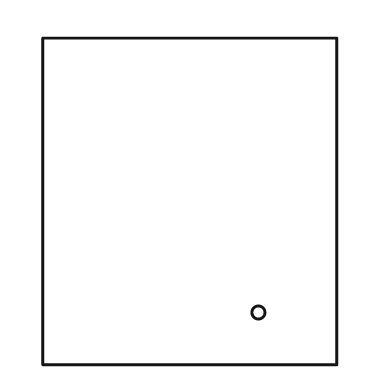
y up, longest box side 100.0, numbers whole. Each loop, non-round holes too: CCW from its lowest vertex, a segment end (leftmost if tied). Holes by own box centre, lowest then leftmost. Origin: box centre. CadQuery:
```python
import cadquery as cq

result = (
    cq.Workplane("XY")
    .moveTo(-45.0, -50.0)
    .lineTo(45.0, -50.0)
    .lineTo(45.0, 50.0)
    .lineTo(-45.0, 50.0)
    .close()
    .moveTo(21.0, -34.0)
    .circle(2.0)
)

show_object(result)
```